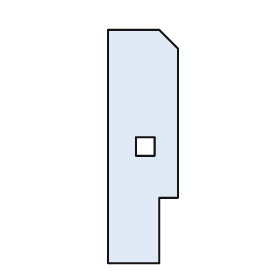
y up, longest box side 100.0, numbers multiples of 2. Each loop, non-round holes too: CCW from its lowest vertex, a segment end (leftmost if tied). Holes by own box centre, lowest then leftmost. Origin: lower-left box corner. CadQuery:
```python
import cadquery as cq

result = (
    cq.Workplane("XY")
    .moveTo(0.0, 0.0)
    .lineTo(22.0, 0.0)
    .lineTo(22.0, 28.0)
    .lineTo(30.0, 28.0)
    .lineTo(30.0, 92.0)
    .lineTo(22.0, 100.0)
    .lineTo(0.0, 100.0)
    .close()
    .moveTo(12.0, 46.0)
    .lineTo(20.0, 46.0)
    .lineTo(20.0, 54.0)
    .lineTo(12.0, 54.0)
    .close()
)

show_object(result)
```